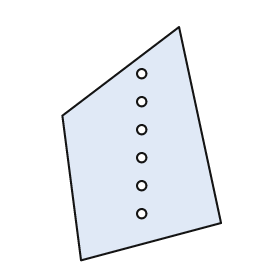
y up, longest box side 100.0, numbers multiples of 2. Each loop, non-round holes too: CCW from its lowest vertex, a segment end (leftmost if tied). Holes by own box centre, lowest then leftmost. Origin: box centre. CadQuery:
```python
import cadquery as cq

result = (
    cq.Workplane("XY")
    .moveTo(-26.0, -50.0)
    .lineTo(34.0, -34.0)
    .lineTo(16.0, 50.0)
    .lineTo(-34.0, 12.0)
    .close()
    .moveTo(0.0, -30.0)
    .circle(2.0)
    .moveTo(0.0, -18.0)
    .circle(2.0)
    .moveTo(0.0, -6.0)
    .circle(2.0)
    .moveTo(0.0, 6.0)
    .circle(2.0)
    .moveTo(0.0, 18.0)
    .circle(2.0)
    .moveTo(0.0, 30.0)
    .circle(2.0)
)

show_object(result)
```